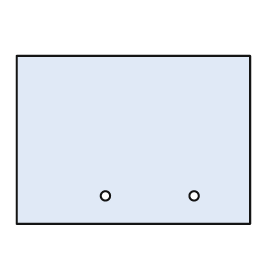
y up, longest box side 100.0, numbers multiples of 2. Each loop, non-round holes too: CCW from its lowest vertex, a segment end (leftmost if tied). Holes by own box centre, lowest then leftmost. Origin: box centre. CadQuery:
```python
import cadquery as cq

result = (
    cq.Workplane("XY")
    .moveTo(-50.0, -36.0)
    .lineTo(50.0, -36.0)
    .lineTo(50.0, 36.0)
    .lineTo(-50.0, 36.0)
    .close()
    .moveTo(-12.0, -24.0)
    .circle(2.0)
    .moveTo(26.0, -24.0)
    .circle(2.0)
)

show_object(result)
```